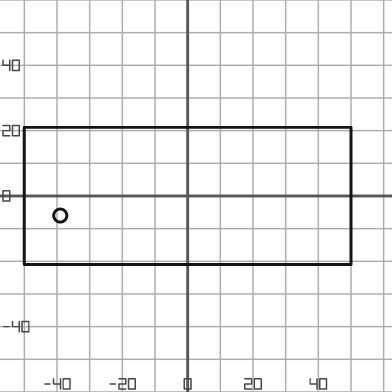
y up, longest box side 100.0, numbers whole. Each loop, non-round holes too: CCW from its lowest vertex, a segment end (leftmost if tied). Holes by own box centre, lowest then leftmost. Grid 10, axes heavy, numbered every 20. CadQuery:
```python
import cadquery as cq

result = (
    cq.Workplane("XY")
    .moveTo(-50.0, -21.0)
    .lineTo(50.0, -21.0)
    .lineTo(50.0, 21.0)
    .lineTo(-50.0, 21.0)
    .close()
    .moveTo(-39.0, -6.0)
    .circle(2.0)
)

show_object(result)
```